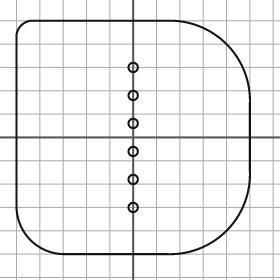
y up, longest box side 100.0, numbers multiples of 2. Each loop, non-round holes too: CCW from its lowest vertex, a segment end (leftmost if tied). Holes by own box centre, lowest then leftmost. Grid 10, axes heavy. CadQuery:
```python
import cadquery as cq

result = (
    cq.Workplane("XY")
    .moveTo(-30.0, -50.0)
    .lineTo(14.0, -50.0)
    .threePointArc((40.0, -40.0), (50.0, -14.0))
    .lineTo(50.0, 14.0)
    .threePointArc((40.0, 40.0), (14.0, 50.0))
    .lineTo(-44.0, 50.0)
    .threePointArc((-48.0, 48.0), (-50.0, 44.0))
    .lineTo(-50.0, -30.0)
    .threePointArc((-44.0, -44.0), (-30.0, -50.0))
    .close()
    .moveTo(0.0, -30.0)
    .circle(2.0)
    .moveTo(0.0, -18.0)
    .circle(2.0)
    .moveTo(0.0, -6.0)
    .circle(2.0)
    .moveTo(0.0, 6.0)
    .circle(2.0)
    .moveTo(0.0, 18.0)
    .circle(2.0)
    .moveTo(0.0, 30.0)
    .circle(2.0)
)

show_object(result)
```